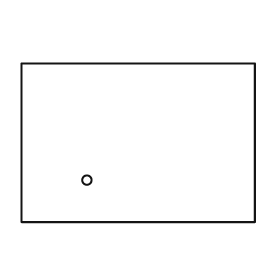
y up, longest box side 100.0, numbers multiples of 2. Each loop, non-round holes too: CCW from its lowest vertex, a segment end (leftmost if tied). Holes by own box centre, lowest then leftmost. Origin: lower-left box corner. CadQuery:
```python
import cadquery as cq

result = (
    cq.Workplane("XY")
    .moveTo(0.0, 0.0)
    .lineTo(100.0, 0.0)
    .lineTo(100.0, 68.0)
    .lineTo(0.0, 68.0)
    .close()
    .moveTo(28.0, 18.0)
    .circle(2.0)
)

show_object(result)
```